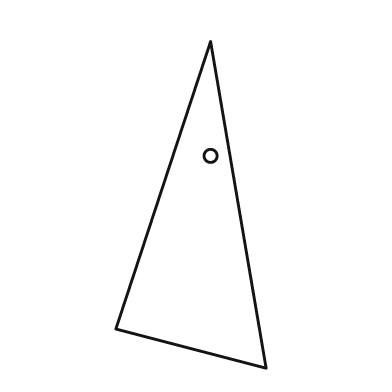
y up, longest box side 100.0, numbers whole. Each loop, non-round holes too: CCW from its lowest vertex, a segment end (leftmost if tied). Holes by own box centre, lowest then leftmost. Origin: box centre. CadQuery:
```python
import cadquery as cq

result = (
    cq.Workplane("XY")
    .moveTo(23.0, -50.0)
    .lineTo(6.0, 50.0)
    .lineTo(-23.0, -38.0)
    .close()
    .moveTo(6.0, 15.0)
    .circle(2.0)
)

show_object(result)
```